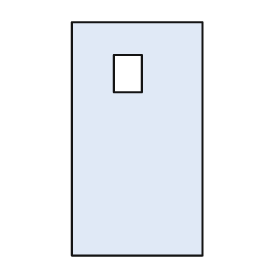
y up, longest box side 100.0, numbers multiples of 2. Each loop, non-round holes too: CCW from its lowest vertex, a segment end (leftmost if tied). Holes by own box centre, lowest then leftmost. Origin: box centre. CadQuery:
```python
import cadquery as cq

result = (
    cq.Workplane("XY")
    .moveTo(-28.0, -50.0)
    .lineTo(28.0, -50.0)
    .lineTo(28.0, 50.0)
    .lineTo(-28.0, 50.0)
    .close()
    .moveTo(-10.0, 20.0)
    .lineTo(2.0, 20.0)
    .lineTo(2.0, 36.0)
    .lineTo(-10.0, 36.0)
    .close()
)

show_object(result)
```